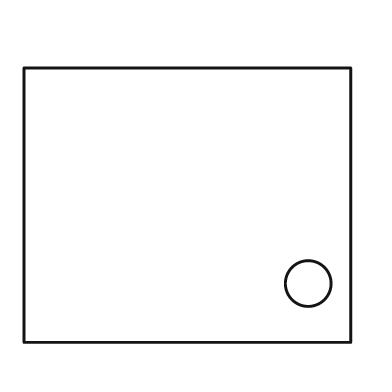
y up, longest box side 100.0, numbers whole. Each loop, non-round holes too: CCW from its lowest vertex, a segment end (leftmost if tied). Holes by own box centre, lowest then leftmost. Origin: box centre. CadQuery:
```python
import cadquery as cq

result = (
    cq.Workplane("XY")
    .moveTo(-50.0, -42.0)
    .lineTo(50.0, -42.0)
    .lineTo(50.0, 42.0)
    .lineTo(-50.0, 42.0)
    .close()
    .moveTo(37.0, -24.0)
    .circle(7.0)
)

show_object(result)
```